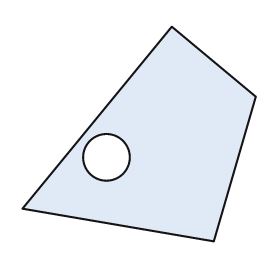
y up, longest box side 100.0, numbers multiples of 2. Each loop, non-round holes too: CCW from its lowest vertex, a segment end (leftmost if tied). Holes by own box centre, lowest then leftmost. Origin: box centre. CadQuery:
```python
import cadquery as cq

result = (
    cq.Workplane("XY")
    .moveTo(32.0, -46.0)
    .lineTo(50.0, 16.0)
    .lineTo(14.0, 46.0)
    .lineTo(-50.0, -32.0)
    .close()
    .moveTo(-14.0, -10.0)
    .circle(10.0)
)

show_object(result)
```